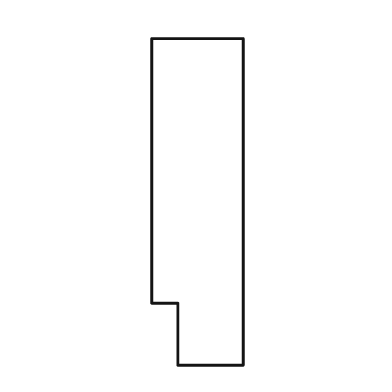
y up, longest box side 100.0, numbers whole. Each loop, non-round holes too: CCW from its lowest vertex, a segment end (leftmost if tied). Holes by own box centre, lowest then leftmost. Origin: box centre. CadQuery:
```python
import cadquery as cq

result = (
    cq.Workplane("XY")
    .moveTo(-6.0, -50.0)
    .lineTo(14.0, -50.0)
    .lineTo(14.0, 50.0)
    .lineTo(-14.0, 50.0)
    .lineTo(-14.0, -31.0)
    .lineTo(-6.0, -31.0)
    .close()
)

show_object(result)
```